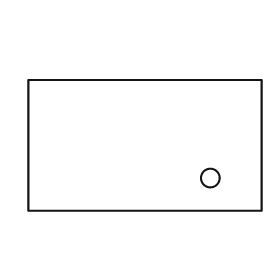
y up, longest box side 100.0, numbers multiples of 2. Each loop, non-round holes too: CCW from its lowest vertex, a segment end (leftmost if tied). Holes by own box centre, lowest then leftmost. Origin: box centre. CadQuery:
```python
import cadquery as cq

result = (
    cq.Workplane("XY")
    .moveTo(-50.0, -28.0)
    .lineTo(50.0, -28.0)
    .lineTo(50.0, 28.0)
    .lineTo(-50.0, 28.0)
    .close()
    .moveTo(28.0, -14.0)
    .circle(4.0)
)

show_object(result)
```